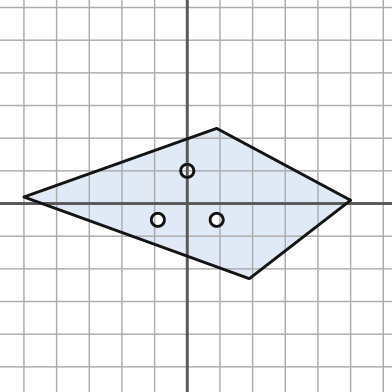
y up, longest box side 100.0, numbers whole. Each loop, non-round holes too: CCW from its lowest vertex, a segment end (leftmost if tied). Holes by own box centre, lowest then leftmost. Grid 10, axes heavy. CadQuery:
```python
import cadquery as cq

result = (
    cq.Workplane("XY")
    .moveTo(19.0, -23.0)
    .lineTo(50.0, 1.0)
    .lineTo(9.0, 23.0)
    .lineTo(-50.0, 2.0)
    .close()
    .moveTo(-9.0, -5.0)
    .circle(2.0)
    .moveTo(9.0, -5.0)
    .circle(2.0)
    .moveTo(0.0, 10.0)
    .circle(2.0)
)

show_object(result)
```